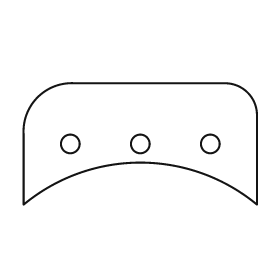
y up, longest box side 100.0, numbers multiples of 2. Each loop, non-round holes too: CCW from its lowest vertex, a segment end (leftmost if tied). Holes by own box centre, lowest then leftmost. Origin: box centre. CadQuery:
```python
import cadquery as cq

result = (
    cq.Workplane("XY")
    .moveTo(-50.0, -26.0)
    .threePointArc((0.0, -8.0), (50.0, -26.0))
    .lineTo(50.0, 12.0)
    .threePointArc((46.0, 22.0), (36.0, 26.0))
    .lineTo(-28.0, 26.0)
    .threePointArc((-44.0, 20.0), (-50.0, 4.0))
    .close()
    .moveTo(-30.0, 0.0)
    .circle(4.0)
    .moveTo(0.0, 0.0)
    .circle(4.0)
    .moveTo(30.0, 0.0)
    .circle(4.0)
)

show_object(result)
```